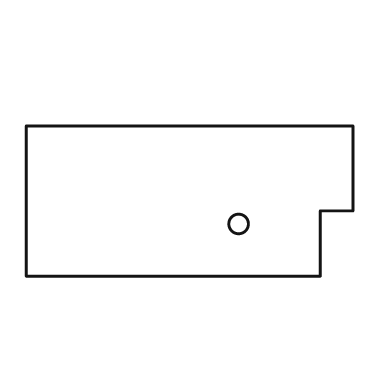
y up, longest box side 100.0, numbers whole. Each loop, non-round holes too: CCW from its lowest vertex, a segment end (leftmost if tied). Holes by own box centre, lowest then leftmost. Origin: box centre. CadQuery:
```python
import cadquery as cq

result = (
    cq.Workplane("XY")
    .moveTo(-50.0, -23.0)
    .lineTo(40.0, -23.0)
    .lineTo(40.0, -3.0)
    .lineTo(50.0, -3.0)
    .lineTo(50.0, 23.0)
    .lineTo(-50.0, 23.0)
    .close()
    .moveTo(15.0, -7.0)
    .circle(3.0)
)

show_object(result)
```